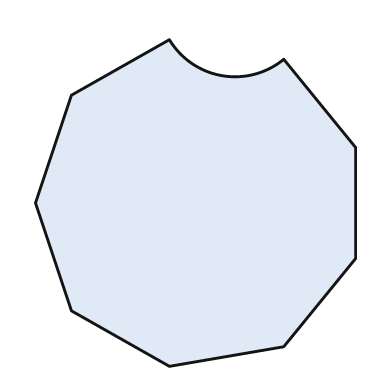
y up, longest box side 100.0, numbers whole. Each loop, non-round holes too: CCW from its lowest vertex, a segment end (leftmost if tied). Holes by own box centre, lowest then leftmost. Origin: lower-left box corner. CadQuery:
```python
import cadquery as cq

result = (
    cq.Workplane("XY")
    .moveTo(41.0, 0.0)
    .lineTo(76.0, 6.0)
    .lineTo(98.0, 33.0)
    .lineTo(98.0, 67.0)
    .lineTo(76.0, 94.0)
    .threePointArc((57.0, 89.0), (41.0, 100.0))
    .lineTo(11.0, 83.0)
    .lineTo(0.0, 50.0)
    .lineTo(11.0, 17.0)
    .close()
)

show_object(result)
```